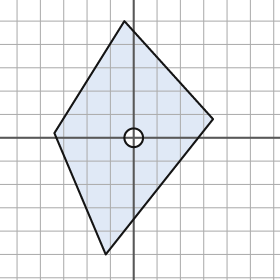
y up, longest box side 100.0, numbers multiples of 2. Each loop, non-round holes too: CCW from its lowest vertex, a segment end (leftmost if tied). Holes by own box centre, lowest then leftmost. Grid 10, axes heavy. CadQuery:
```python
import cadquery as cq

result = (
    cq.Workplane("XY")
    .moveTo(-12.0, -50.0)
    .lineTo(34.0, 8.0)
    .lineTo(-4.0, 50.0)
    .lineTo(-34.0, 2.0)
    .close()
    .moveTo(0.0, 0.0)
    .circle(4.0)
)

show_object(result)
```